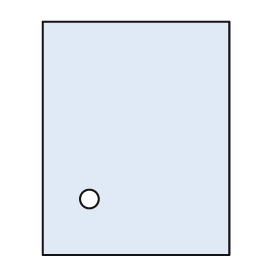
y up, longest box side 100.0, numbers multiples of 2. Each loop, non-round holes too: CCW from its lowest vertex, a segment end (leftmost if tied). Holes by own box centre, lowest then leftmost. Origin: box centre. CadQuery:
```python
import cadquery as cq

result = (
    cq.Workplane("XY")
    .moveTo(-40.0, -50.0)
    .lineTo(40.0, -50.0)
    .lineTo(40.0, 50.0)
    .lineTo(-40.0, 50.0)
    .close()
    .moveTo(-20.0, -26.0)
    .circle(4.0)
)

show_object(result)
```